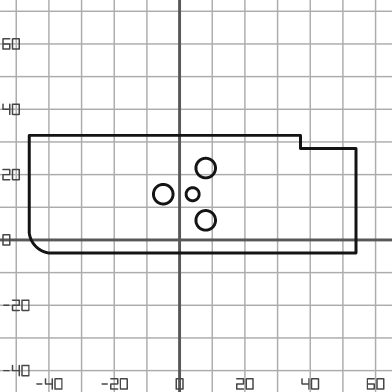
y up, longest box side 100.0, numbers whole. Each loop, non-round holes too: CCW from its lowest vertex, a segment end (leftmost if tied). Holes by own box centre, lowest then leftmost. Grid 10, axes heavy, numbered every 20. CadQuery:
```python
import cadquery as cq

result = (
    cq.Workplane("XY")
    .moveTo(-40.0, -4.0)
    .lineTo(54.0, -4.0)
    .lineTo(54.0, 28.0)
    .lineTo(37.0, 28.0)
    .lineTo(37.0, 32.0)
    .lineTo(-46.0, 32.0)
    .lineTo(-46.0, 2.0)
    .threePointArc((-44.0, -2.0), (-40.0, -4.0))
    .close()
    .moveTo(8.0, 6.0)
    .circle(3.0)
    .moveTo(-5.0, 14.0)
    .circle(3.0)
    .moveTo(4.0, 14.0)
    .circle(2.0)
    .moveTo(8.0, 22.0)
    .circle(3.0)
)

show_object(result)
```